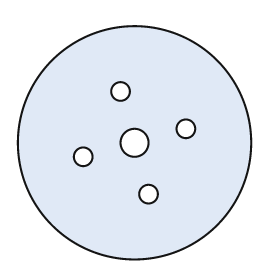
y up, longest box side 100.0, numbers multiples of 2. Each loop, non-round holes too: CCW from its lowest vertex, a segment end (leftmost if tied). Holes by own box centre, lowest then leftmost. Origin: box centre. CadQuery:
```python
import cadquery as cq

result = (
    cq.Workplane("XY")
    .moveTo(0.0, 0.0)
    .circle(50.0)
    .moveTo(6.0, -22.0)
    .circle(4.0)
    .moveTo(-22.0, -6.0)
    .circle(4.0)
    .moveTo(0.0, 0.0)
    .circle(6.0)
    .moveTo(22.0, 6.0)
    .circle(4.0)
    .moveTo(-6.0, 22.0)
    .circle(4.0)
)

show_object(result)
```